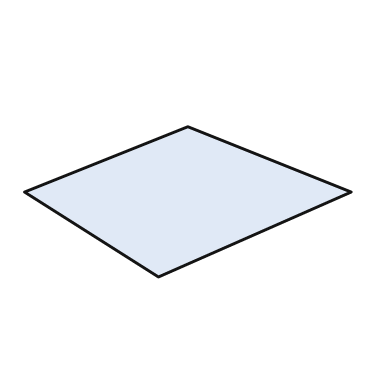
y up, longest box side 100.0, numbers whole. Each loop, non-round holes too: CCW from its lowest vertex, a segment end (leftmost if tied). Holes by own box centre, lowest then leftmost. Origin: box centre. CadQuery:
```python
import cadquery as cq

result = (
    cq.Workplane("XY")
    .moveTo(-9.0, -23.0)
    .lineTo(50.0, 3.0)
    .lineTo(0.0, 23.0)
    .lineTo(-50.0, 3.0)
    .close()
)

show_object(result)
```